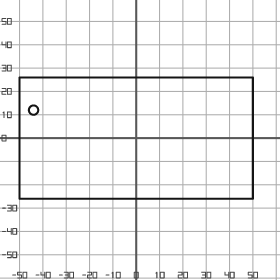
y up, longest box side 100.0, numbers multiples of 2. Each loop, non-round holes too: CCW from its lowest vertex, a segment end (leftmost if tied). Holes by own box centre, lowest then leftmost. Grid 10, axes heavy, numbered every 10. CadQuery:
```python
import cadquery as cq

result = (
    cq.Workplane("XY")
    .moveTo(-50.0, -26.0)
    .lineTo(50.0, -26.0)
    .lineTo(50.0, 26.0)
    .lineTo(-50.0, 26.0)
    .close()
    .moveTo(-44.0, 12.0)
    .circle(2.0)
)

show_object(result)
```